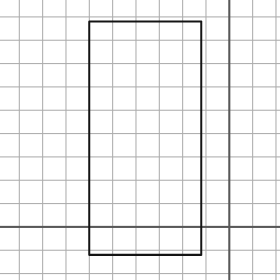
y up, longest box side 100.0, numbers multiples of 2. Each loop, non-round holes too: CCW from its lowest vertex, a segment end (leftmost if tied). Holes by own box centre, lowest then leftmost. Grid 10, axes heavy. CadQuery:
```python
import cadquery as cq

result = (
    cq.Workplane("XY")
    .moveTo(-60.0, -12.0)
    .lineTo(-12.0, -12.0)
    .lineTo(-12.0, 88.0)
    .lineTo(-60.0, 88.0)
    .close()
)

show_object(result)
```